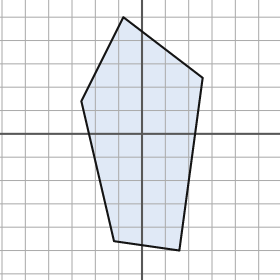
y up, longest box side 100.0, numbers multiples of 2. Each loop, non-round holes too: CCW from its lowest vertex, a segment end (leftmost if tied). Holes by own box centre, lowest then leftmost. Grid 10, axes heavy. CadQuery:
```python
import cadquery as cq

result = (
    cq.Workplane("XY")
    .moveTo(16.0, -50.0)
    .lineTo(26.0, 24.0)
    .lineTo(-8.0, 50.0)
    .lineTo(-26.0, 14.0)
    .lineTo(-12.0, -46.0)
    .close()
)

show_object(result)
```